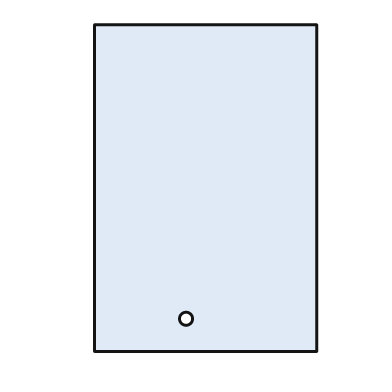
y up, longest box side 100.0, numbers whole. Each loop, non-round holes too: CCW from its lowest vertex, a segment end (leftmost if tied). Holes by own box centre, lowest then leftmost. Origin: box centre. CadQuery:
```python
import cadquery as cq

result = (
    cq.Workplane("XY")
    .moveTo(-34.0, -50.0)
    .lineTo(34.0, -50.0)
    .lineTo(34.0, 50.0)
    .lineTo(-34.0, 50.0)
    .close()
    .moveTo(-6.0, -40.0)
    .circle(2.0)
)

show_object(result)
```